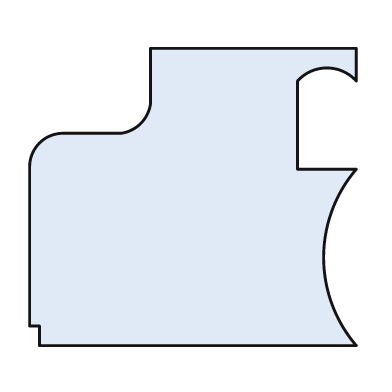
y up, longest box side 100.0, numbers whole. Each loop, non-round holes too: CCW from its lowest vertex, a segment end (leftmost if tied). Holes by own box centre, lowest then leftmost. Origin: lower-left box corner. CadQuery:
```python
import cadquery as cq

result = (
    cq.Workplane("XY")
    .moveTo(3.0, 0.0)
    .lineTo(100.0, 0.0)
    .threePointArc((90.0, 27.0), (100.0, 54.0))
    .lineTo(82.0, 54.0)
    .lineTo(82.0, 81.0)
    .threePointArc((91.0, 85.0), (100.0, 81.0))
    .lineTo(100.0, 91.0)
    .lineTo(37.0, 91.0)
    .lineTo(37.0, 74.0)
    .threePointArc((34.0, 68.0), (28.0, 65.0))
    .lineTo(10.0, 65.0)
    .threePointArc((3.0, 62.0), (0.0, 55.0))
    .lineTo(0.0, 6.0)
    .lineTo(3.0, 6.0)
    .close()
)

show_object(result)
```